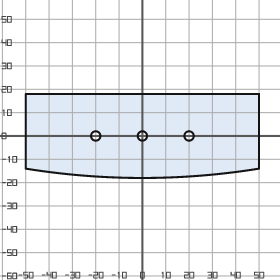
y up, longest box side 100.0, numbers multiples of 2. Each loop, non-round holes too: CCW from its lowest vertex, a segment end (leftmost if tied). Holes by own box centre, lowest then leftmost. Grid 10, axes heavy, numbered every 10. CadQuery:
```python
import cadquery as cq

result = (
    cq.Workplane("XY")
    .moveTo(-50.0, -14.0)
    .threePointArc((0.0, -18.0), (50.0, -14.0))
    .lineTo(50.0, 18.0)
    .lineTo(-50.0, 18.0)
    .close()
    .moveTo(-20.0, 0.0)
    .circle(2.0)
    .moveTo(0.0, 0.0)
    .circle(2.0)
    .moveTo(20.0, 0.0)
    .circle(2.0)
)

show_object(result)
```